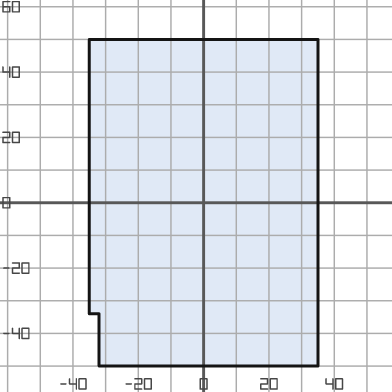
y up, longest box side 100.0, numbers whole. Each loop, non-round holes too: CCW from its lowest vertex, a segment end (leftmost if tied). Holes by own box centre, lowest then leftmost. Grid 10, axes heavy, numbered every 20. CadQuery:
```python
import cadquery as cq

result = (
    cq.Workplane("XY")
    .moveTo(-32.0, -50.0)
    .lineTo(35.0, -50.0)
    .lineTo(35.0, 50.0)
    .lineTo(-35.0, 50.0)
    .lineTo(-35.0, -34.0)
    .lineTo(-32.0, -34.0)
    .close()
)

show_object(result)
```